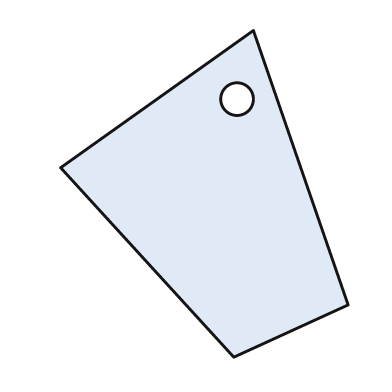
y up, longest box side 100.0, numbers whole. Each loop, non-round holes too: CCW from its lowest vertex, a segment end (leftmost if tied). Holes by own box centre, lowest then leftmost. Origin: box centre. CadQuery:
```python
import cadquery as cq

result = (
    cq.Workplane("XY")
    .moveTo(9.0, -50.0)
    .lineTo(44.0, -34.0)
    .lineTo(15.0, 50.0)
    .lineTo(-44.0, 8.0)
    .close()
    .moveTo(10.0, 29.0)
    .circle(5.0)
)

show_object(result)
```